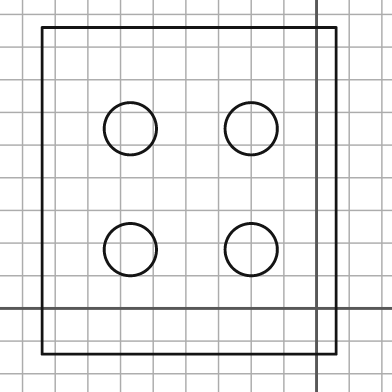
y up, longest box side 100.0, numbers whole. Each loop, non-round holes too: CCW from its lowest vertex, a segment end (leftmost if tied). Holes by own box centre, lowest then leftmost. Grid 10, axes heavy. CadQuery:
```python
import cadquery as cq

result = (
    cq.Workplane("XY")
    .moveTo(-84.0, -14.0)
    .lineTo(6.0, -14.0)
    .lineTo(6.0, 86.0)
    .lineTo(-84.0, 86.0)
    .close()
    .moveTo(-57.0, 18.0)
    .circle(8.0)
    .moveTo(-20.0, 18.0)
    .circle(8.0)
    .moveTo(-57.0, 55.0)
    .circle(8.0)
    .moveTo(-20.0, 55.0)
    .circle(8.0)
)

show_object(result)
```